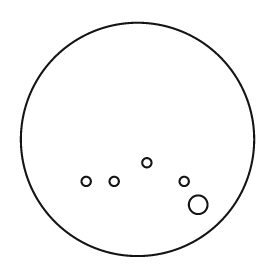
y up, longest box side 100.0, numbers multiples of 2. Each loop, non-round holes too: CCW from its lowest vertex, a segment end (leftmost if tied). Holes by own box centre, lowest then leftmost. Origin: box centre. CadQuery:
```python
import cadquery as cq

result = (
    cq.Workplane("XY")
    .moveTo(0.0, 0.0)
    .circle(50.0)
    .moveTo(26.0, -28.0)
    .circle(4.0)
    .moveTo(-22.0, -18.0)
    .circle(2.0)
    .moveTo(-10.0, -18.0)
    .circle(2.0)
    .moveTo(20.0, -18.0)
    .circle(2.0)
    .moveTo(4.0, -10.0)
    .circle(2.0)
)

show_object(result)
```